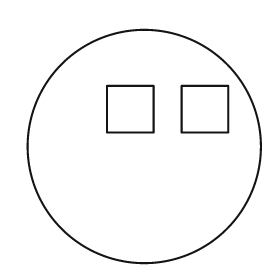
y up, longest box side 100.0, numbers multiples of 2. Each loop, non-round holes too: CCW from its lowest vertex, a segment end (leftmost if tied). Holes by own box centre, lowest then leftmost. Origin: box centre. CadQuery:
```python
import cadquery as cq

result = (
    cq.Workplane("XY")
    .moveTo(0.0, 0.0)
    .circle(50.0)
    .moveTo(-16.0, 6.0)
    .lineTo(4.0, 6.0)
    .lineTo(4.0, 26.0)
    .lineTo(-16.0, 26.0)
    .close()
    .moveTo(16.0, 6.0)
    .lineTo(36.0, 6.0)
    .lineTo(36.0, 26.0)
    .lineTo(16.0, 26.0)
    .close()
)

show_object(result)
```